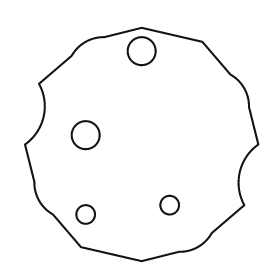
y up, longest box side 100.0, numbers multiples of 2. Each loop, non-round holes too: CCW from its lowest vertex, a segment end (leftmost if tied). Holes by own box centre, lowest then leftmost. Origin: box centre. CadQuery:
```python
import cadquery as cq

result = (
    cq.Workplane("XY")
    .moveTo(0.0, -50.0)
    .lineTo(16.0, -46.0)
    .threePointArc((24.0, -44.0), (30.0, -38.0))
    .lineTo(44.0, -26.0)
    .threePointArc((42.0, -12.0), (50.0, 0.0))
    .lineTo(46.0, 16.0)
    .threePointArc((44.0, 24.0), (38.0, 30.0))
    .lineTo(26.0, 44.0)
    .lineTo(0.0, 50.0)
    .lineTo(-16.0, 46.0)
    .threePointArc((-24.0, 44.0), (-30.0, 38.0))
    .lineTo(-44.0, 26.0)
    .threePointArc((-42.0, 12.0), (-50.0, 0.0))
    .lineTo(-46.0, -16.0)
    .threePointArc((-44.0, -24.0), (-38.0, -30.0))
    .lineTo(-26.0, -44.0)
    .close()
    .moveTo(-24.0, -30.0)
    .circle(4.0)
    .moveTo(12.0, -26.0)
    .circle(4.0)
    .moveTo(-24.0, 4.0)
    .circle(6.0)
    .moveTo(0.0, 40.0)
    .circle(6.0)
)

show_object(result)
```